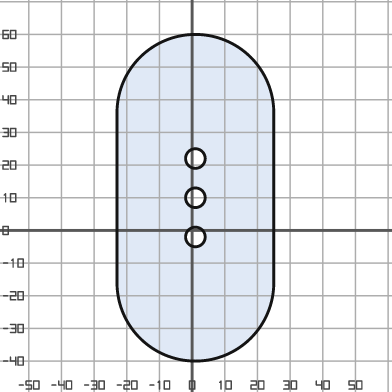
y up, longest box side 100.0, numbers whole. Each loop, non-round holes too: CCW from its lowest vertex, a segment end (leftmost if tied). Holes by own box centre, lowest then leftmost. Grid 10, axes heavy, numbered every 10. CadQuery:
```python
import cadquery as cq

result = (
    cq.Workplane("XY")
    .moveTo(-23.0, -16.0)
    .threePointArc((1.0, -40.0), (25.0, -16.0))
    .lineTo(25.0, 36.0)
    .threePointArc((1.0, 60.0), (-23.0, 36.0))
    .close()
    .moveTo(1.0, -2.0)
    .circle(3.0)
    .moveTo(1.0, 10.0)
    .circle(3.0)
    .moveTo(1.0, 22.0)
    .circle(3.0)
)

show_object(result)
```